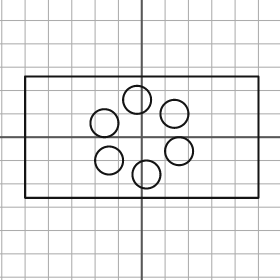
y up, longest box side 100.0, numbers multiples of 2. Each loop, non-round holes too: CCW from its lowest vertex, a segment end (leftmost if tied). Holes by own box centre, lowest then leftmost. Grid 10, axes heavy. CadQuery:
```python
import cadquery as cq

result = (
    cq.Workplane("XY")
    .moveTo(-50.0, -26.0)
    .lineTo(50.0, -26.0)
    .lineTo(50.0, 26.0)
    .lineTo(-50.0, 26.0)
    .close()
    .moveTo(2.0, -16.0)
    .circle(6.0)
    .moveTo(-14.0, -10.0)
    .circle(6.0)
    .moveTo(16.0, -6.0)
    .circle(6.0)
    .moveTo(-16.0, 6.0)
    .circle(6.0)
    .moveTo(14.0, 10.0)
    .circle(6.0)
    .moveTo(-2.0, 16.0)
    .circle(6.0)
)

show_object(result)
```